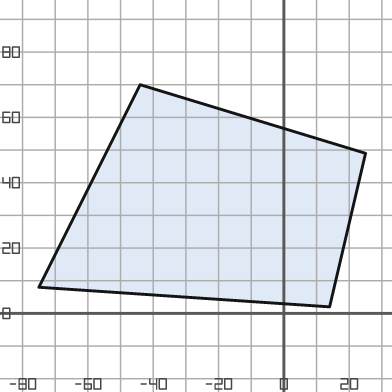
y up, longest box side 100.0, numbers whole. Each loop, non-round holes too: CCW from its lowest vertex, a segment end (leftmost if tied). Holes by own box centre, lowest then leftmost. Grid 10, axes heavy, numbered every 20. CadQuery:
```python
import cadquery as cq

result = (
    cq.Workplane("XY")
    .moveTo(14.0, 2.0)
    .lineTo(25.0, 49.0)
    .lineTo(-44.0, 70.0)
    .lineTo(-75.0, 8.0)
    .close()
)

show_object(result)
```